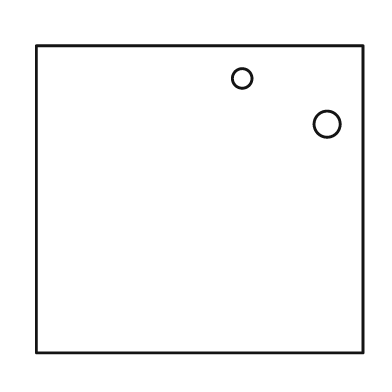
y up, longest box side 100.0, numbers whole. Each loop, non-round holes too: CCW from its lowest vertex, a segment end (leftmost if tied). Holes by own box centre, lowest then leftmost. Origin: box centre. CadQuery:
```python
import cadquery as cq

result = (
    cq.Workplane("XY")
    .moveTo(-50.0, -47.0)
    .lineTo(50.0, -47.0)
    .lineTo(50.0, 47.0)
    .lineTo(-50.0, 47.0)
    .close()
    .moveTo(39.0, 23.0)
    .circle(4.0)
    .moveTo(13.0, 37.0)
    .circle(3.0)
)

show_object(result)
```